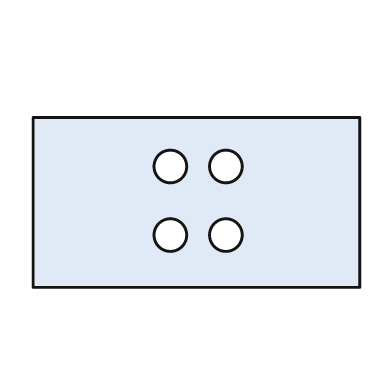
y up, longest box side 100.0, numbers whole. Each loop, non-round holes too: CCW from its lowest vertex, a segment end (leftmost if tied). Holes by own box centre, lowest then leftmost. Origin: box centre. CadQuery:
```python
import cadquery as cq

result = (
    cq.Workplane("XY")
    .moveTo(-50.0, -26.0)
    .lineTo(50.0, -26.0)
    .lineTo(50.0, 26.0)
    .lineTo(-50.0, 26.0)
    .close()
    .moveTo(-8.0, -10.0)
    .circle(5.0)
    .moveTo(9.0, -10.0)
    .circle(5.0)
    .moveTo(-8.0, 11.0)
    .circle(5.0)
    .moveTo(9.0, 11.0)
    .circle(5.0)
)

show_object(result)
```